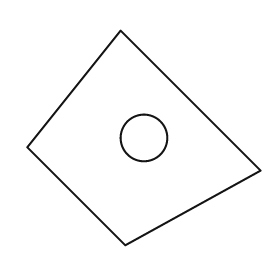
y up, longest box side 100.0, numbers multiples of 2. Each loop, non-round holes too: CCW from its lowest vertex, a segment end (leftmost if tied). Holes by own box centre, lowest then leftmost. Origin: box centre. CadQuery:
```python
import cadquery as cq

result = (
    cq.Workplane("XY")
    .moveTo(-8.0, -46.0)
    .lineTo(50.0, -14.0)
    .lineTo(-10.0, 46.0)
    .lineTo(-50.0, -4.0)
    .close()
    .moveTo(0.0, 0.0)
    .circle(10.0)
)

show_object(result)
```